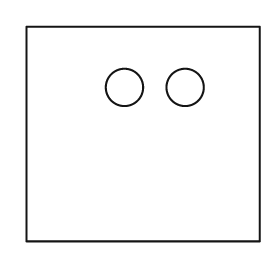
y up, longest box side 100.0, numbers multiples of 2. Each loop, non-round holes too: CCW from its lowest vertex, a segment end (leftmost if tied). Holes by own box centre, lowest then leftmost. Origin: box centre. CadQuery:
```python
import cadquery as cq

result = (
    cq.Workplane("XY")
    .moveTo(-50.0, -46.0)
    .lineTo(50.0, -46.0)
    .lineTo(50.0, 46.0)
    .lineTo(-50.0, 46.0)
    .close()
    .moveTo(-8.0, 20.0)
    .circle(8.0)
    .moveTo(18.0, 20.0)
    .circle(8.0)
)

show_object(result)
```